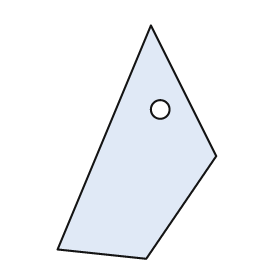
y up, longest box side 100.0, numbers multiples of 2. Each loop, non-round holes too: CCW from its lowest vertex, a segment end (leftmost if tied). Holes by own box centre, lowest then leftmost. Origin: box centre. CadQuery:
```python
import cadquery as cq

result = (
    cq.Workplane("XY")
    .moveTo(4.0, -50.0)
    .lineTo(34.0, -6.0)
    .lineTo(6.0, 50.0)
    .lineTo(-34.0, -46.0)
    .close()
    .moveTo(10.0, 14.0)
    .circle(4.0)
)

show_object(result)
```